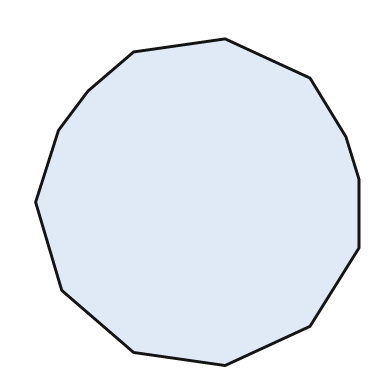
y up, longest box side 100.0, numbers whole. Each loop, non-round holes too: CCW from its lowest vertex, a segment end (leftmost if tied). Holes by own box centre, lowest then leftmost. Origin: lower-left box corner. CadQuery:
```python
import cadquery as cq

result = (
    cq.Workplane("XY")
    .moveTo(58.0, 0.0)
    .lineTo(84.0, 12.0)
    .lineTo(99.0, 36.0)
    .lineTo(99.0, 57.0)
    .lineTo(95.0, 70.0)
    .lineTo(84.0, 88.0)
    .lineTo(58.0, 100.0)
    .lineTo(30.0, 96.0)
    .lineTo(16.0, 84.0)
    .lineTo(7.0, 72.0)
    .lineTo(0.0, 50.0)
    .lineTo(8.0, 23.0)
    .lineTo(30.0, 4.0)
    .close()
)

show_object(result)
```